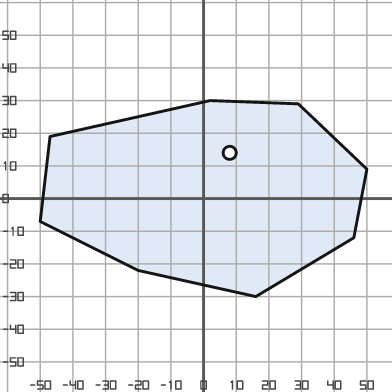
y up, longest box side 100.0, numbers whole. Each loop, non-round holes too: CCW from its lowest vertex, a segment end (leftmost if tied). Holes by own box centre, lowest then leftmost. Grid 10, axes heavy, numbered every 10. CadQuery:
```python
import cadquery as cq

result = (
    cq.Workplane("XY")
    .moveTo(16.0, -30.0)
    .lineTo(46.0, -12.0)
    .lineTo(50.0, 9.0)
    .lineTo(29.0, 29.0)
    .lineTo(2.0, 30.0)
    .lineTo(-47.0, 19.0)
    .lineTo(-50.0, -7.0)
    .lineTo(-20.0, -22.0)
    .close()
    .moveTo(8.0, 14.0)
    .circle(2.0)
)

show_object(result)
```